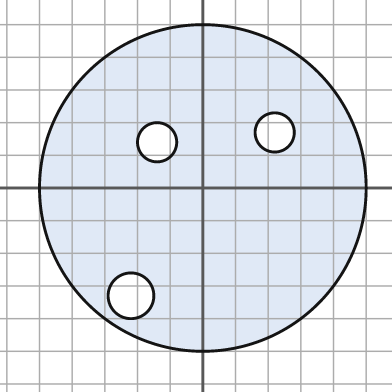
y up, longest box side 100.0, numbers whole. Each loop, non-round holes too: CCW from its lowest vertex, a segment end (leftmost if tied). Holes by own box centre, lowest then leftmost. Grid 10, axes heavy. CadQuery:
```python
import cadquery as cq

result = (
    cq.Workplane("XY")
    .moveTo(0.0, 0.0)
    .circle(50.0)
    .moveTo(-22.0, -33.0)
    .circle(7.0)
    .moveTo(-14.0, 14.0)
    .circle(6.0)
    .moveTo(22.0, 17.0)
    .circle(6.0)
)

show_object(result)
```